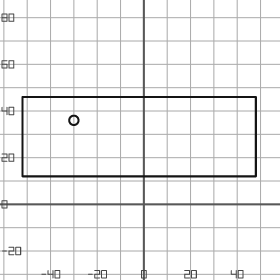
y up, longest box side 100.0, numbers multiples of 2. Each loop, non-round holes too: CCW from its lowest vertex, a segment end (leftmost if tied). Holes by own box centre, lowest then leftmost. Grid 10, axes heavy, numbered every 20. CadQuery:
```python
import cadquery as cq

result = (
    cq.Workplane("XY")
    .moveTo(-52.0, 12.0)
    .lineTo(48.0, 12.0)
    .lineTo(48.0, 46.0)
    .lineTo(-52.0, 46.0)
    .close()
    .moveTo(-30.0, 36.0)
    .circle(2.0)
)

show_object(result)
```